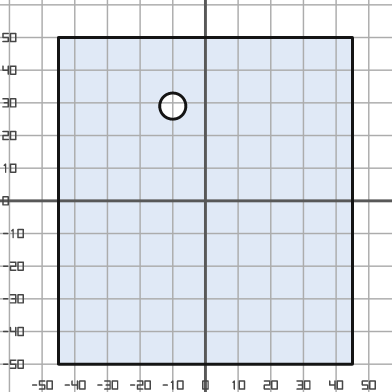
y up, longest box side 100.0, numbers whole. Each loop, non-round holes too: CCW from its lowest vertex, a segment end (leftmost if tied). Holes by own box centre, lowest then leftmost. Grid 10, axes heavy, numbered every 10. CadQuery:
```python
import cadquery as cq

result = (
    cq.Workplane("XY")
    .moveTo(-45.0, -50.0)
    .lineTo(45.0, -50.0)
    .lineTo(45.0, 50.0)
    .lineTo(-45.0, 50.0)
    .close()
    .moveTo(-10.0, 29.0)
    .circle(4.0)
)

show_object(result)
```